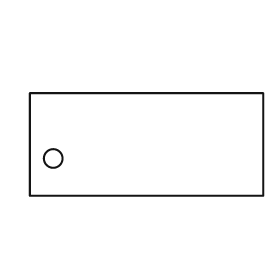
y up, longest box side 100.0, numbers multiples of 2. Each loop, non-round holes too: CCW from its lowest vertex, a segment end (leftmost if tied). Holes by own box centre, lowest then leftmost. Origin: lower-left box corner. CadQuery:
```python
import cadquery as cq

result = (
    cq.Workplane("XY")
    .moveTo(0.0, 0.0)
    .lineTo(100.0, 0.0)
    .lineTo(100.0, 44.0)
    .lineTo(0.0, 44.0)
    .close()
    .moveTo(10.0, 16.0)
    .circle(4.0)
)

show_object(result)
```